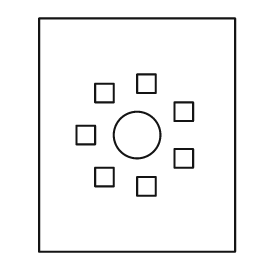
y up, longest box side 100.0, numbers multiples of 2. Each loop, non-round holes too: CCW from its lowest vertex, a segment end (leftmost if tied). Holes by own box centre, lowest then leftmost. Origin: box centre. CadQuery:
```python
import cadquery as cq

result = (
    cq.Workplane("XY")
    .moveTo(-42.0, -50.0)
    .lineTo(42.0, -50.0)
    .lineTo(42.0, 50.0)
    .lineTo(-42.0, 50.0)
    .close()
    .moveTo(0.0, -26.0)
    .lineTo(8.0, -26.0)
    .lineTo(8.0, -18.0)
    .lineTo(0.0, -18.0)
    .close()
    .moveTo(-18.0, -22.0)
    .lineTo(-10.0, -22.0)
    .lineTo(-10.0, -14.0)
    .lineTo(-18.0, -14.0)
    .close()
    .moveTo(16.0, -14.0)
    .lineTo(24.0, -14.0)
    .lineTo(24.0, -6.0)
    .lineTo(16.0, -6.0)
    .close()
    .moveTo(-26.0, -4.0)
    .lineTo(-18.0, -4.0)
    .lineTo(-18.0, 4.0)
    .lineTo(-26.0, 4.0)
    .close()
    .moveTo(0.0, 0.0)
    .circle(10.0)
    .moveTo(16.0, 6.0)
    .lineTo(24.0, 6.0)
    .lineTo(24.0, 14.0)
    .lineTo(16.0, 14.0)
    .close()
    .moveTo(-18.0, 14.0)
    .lineTo(-10.0, 14.0)
    .lineTo(-10.0, 22.0)
    .lineTo(-18.0, 22.0)
    .close()
    .moveTo(0.0, 18.0)
    .lineTo(8.0, 18.0)
    .lineTo(8.0, 26.0)
    .lineTo(0.0, 26.0)
    .close()
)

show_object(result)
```